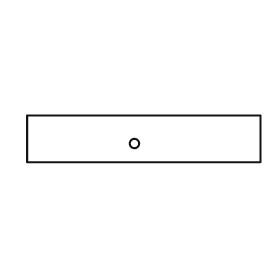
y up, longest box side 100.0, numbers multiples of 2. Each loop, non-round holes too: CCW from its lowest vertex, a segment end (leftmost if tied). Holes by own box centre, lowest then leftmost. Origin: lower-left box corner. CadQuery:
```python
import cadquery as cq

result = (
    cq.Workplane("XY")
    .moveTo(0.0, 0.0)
    .lineTo(100.0, 0.0)
    .lineTo(100.0, 20.0)
    .lineTo(0.0, 20.0)
    .close()
    .moveTo(46.0, 8.0)
    .circle(2.0)
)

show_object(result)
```